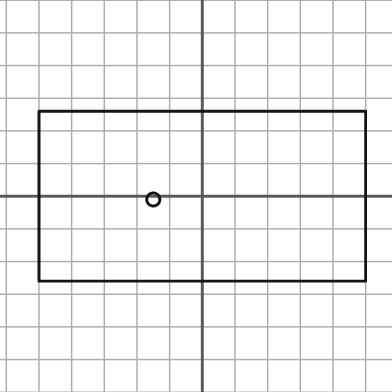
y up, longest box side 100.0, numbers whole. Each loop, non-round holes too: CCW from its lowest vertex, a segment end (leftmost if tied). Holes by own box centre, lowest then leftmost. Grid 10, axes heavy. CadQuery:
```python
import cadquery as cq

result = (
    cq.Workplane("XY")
    .moveTo(-50.0, -26.0)
    .lineTo(50.0, -26.0)
    .lineTo(50.0, 26.0)
    .lineTo(-50.0, 26.0)
    .close()
    .moveTo(-15.0, -1.0)
    .circle(2.0)
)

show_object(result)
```